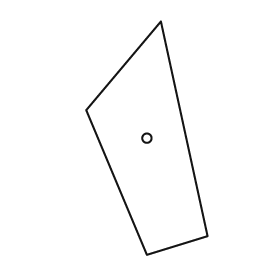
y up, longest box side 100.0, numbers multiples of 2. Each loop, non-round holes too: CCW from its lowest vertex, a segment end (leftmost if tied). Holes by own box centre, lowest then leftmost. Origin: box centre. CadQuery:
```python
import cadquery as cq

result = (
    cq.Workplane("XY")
    .moveTo(0.0, -50.0)
    .lineTo(26.0, -42.0)
    .lineTo(6.0, 50.0)
    .lineTo(-26.0, 12.0)
    .close()
    .moveTo(0.0, 0.0)
    .circle(2.0)
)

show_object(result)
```